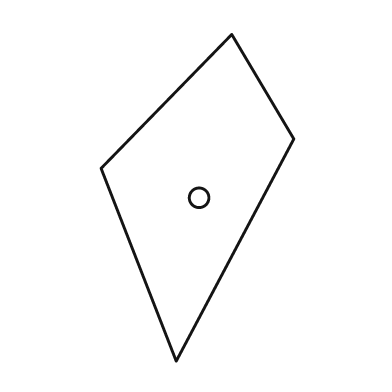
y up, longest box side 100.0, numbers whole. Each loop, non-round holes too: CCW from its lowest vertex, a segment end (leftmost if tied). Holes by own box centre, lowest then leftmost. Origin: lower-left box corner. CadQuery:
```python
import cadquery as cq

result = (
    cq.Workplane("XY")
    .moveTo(23.0, 0.0)
    .lineTo(59.0, 68.0)
    .lineTo(40.0, 100.0)
    .lineTo(0.0, 59.0)
    .close()
    .moveTo(30.0, 50.0)
    .circle(3.0)
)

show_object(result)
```